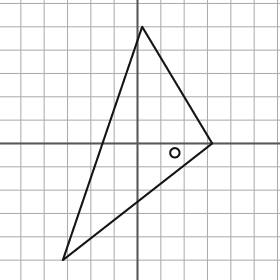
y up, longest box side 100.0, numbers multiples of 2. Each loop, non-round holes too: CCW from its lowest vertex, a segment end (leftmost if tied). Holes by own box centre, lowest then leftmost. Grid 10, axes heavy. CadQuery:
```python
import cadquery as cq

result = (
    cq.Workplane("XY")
    .moveTo(-32.0, -50.0)
    .lineTo(32.0, 0.0)
    .lineTo(2.0, 50.0)
    .close()
    .moveTo(16.0, -4.0)
    .circle(2.0)
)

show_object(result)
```